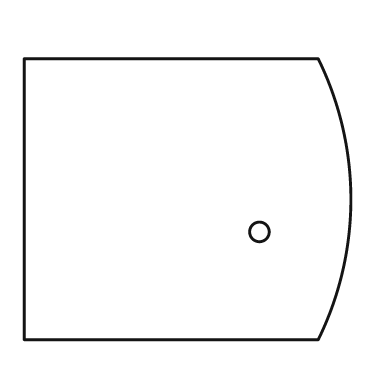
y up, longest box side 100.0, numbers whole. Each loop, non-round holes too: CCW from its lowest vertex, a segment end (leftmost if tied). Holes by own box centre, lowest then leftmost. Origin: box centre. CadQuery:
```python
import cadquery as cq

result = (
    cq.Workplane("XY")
    .moveTo(-50.0, -43.0)
    .lineTo(40.0, -43.0)
    .threePointArc((50.0, 0.0), (40.0, 43.0))
    .lineTo(-50.0, 43.0)
    .close()
    .moveTo(22.0, -10.0)
    .circle(3.0)
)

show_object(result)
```